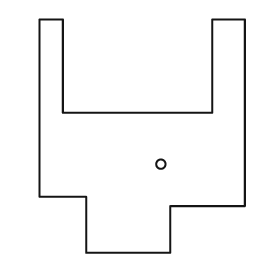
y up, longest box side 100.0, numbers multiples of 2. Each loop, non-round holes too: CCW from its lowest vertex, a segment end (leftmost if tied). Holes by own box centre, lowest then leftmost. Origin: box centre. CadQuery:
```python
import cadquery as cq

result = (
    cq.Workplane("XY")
    .moveTo(-24.0, -50.0)
    .lineTo(12.0, -50.0)
    .lineTo(12.0, -30.0)
    .lineTo(44.0, -30.0)
    .lineTo(44.0, 50.0)
    .lineTo(30.0, 50.0)
    .lineTo(30.0, 10.0)
    .lineTo(-34.0, 10.0)
    .lineTo(-34.0, 50.0)
    .lineTo(-44.0, 50.0)
    .lineTo(-44.0, -26.0)
    .lineTo(-24.0, -26.0)
    .close()
    .moveTo(8.0, -12.0)
    .circle(2.0)
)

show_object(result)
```